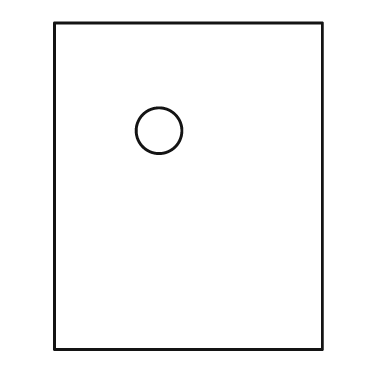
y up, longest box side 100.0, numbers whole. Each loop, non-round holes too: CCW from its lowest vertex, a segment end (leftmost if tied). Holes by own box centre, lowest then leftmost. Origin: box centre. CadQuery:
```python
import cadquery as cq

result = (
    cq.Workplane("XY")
    .moveTo(-41.0, -50.0)
    .lineTo(41.0, -50.0)
    .lineTo(41.0, 50.0)
    .lineTo(-41.0, 50.0)
    .close()
    .moveTo(-9.0, 17.0)
    .circle(7.0)
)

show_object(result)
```